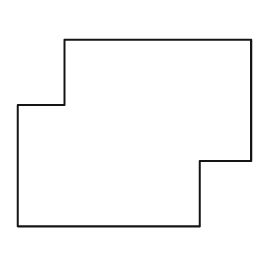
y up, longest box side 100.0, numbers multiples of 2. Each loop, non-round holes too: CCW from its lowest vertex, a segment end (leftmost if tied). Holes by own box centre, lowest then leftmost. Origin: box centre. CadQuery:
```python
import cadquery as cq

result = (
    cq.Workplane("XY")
    .moveTo(-50.0, -40.0)
    .lineTo(28.0, -40.0)
    .lineTo(28.0, -12.0)
    .lineTo(50.0, -12.0)
    .lineTo(50.0, 40.0)
    .lineTo(-30.0, 40.0)
    .lineTo(-30.0, 12.0)
    .lineTo(-50.0, 12.0)
    .close()
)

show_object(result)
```